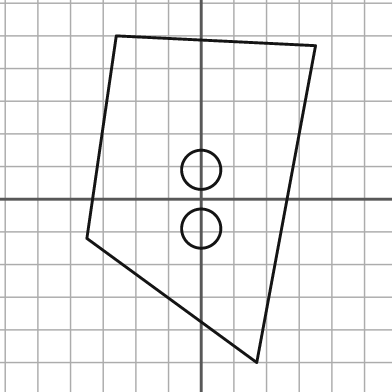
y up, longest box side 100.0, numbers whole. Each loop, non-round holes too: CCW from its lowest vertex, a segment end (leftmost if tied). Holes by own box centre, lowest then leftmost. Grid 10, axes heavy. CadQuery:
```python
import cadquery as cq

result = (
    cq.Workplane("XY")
    .moveTo(17.0, -50.0)
    .lineTo(35.0, 47.0)
    .lineTo(-26.0, 50.0)
    .lineTo(-35.0, -12.0)
    .close()
    .moveTo(0.0, -9.0)
    .circle(6.0)
    .moveTo(0.0, 9.0)
    .circle(6.0)
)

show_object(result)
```